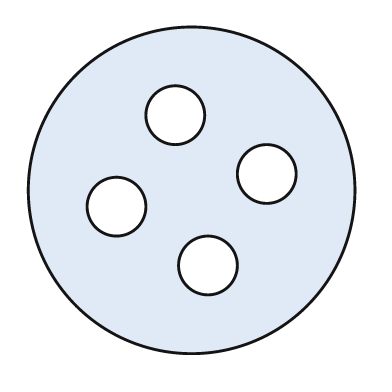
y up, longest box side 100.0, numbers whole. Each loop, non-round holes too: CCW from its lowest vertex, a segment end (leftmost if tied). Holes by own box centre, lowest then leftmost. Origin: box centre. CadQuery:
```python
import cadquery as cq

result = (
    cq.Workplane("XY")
    .moveTo(0.0, 0.0)
    .circle(50.0)
    .moveTo(5.0, -23.0)
    .circle(9.0)
    .moveTo(-23.0, -5.0)
    .circle(9.0)
    .moveTo(23.0, 5.0)
    .circle(9.0)
    .moveTo(-5.0, 23.0)
    .circle(9.0)
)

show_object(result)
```